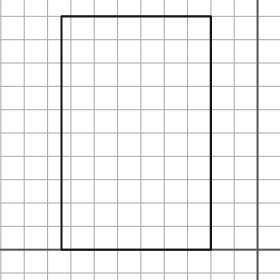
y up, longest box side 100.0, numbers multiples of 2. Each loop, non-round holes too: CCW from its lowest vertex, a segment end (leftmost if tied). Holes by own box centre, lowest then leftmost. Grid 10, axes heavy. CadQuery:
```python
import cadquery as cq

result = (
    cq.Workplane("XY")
    .moveTo(-84.0, 0.0)
    .lineTo(-20.0, 0.0)
    .lineTo(-20.0, 100.0)
    .lineTo(-84.0, 100.0)
    .close()
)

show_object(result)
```